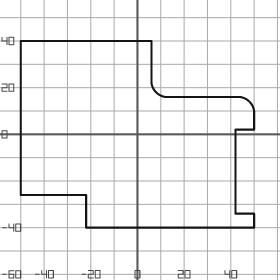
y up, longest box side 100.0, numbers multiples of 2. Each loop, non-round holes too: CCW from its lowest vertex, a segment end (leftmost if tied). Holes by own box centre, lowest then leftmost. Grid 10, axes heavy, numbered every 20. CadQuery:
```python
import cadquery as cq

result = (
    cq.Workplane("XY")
    .moveTo(-22.0, -40.0)
    .lineTo(50.0, -40.0)
    .lineTo(50.0, -34.0)
    .lineTo(42.0, -34.0)
    .lineTo(42.0, 2.0)
    .lineTo(50.0, 2.0)
    .lineTo(50.0, 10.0)
    .threePointArc((48.0, 14.0), (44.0, 16.0))
    .lineTo(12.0, 16.0)
    .threePointArc((8.0, 18.0), (6.0, 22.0))
    .lineTo(6.0, 40.0)
    .lineTo(-50.0, 40.0)
    .lineTo(-50.0, -26.0)
    .lineTo(-22.0, -26.0)
    .close()
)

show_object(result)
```